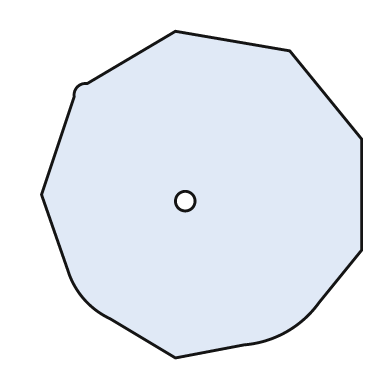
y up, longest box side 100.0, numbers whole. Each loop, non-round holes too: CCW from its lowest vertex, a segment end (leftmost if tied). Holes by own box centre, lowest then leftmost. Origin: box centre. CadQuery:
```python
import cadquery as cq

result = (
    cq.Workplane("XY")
    .moveTo(-8.0, -50.0)
    .lineTo(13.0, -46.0)
    .threePointArc((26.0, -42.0), (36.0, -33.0))
    .lineTo(49.0, -17.0)
    .lineTo(49.0, 17.0)
    .lineTo(27.0, 44.0)
    .lineTo(-8.0, 50.0)
    .lineTo(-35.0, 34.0)
    .threePointArc((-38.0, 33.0), (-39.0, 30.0))
    .lineTo(-49.0, 0.0)
    .lineTo(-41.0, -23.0)
    .threePointArc((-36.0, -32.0), (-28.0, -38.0))
    .close()
    .moveTo(-5.0, -2.0)
    .circle(3.0)
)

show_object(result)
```